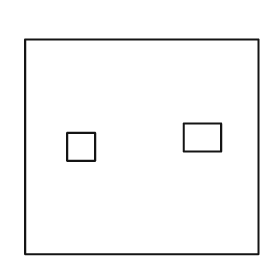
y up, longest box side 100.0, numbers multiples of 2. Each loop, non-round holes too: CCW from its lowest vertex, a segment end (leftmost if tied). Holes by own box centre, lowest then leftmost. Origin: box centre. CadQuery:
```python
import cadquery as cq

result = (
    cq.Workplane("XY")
    .moveTo(-50.0, -46.0)
    .lineTo(50.0, -46.0)
    .lineTo(50.0, 46.0)
    .lineTo(-50.0, 46.0)
    .close()
    .moveTo(-32.0, -6.0)
    .lineTo(-20.0, -6.0)
    .lineTo(-20.0, 6.0)
    .lineTo(-32.0, 6.0)
    .close()
    .moveTo(18.0, -2.0)
    .lineTo(34.0, -2.0)
    .lineTo(34.0, 10.0)
    .lineTo(18.0, 10.0)
    .close()
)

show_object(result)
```